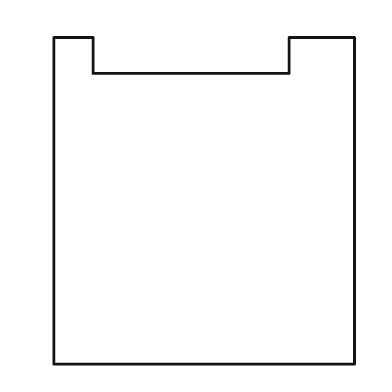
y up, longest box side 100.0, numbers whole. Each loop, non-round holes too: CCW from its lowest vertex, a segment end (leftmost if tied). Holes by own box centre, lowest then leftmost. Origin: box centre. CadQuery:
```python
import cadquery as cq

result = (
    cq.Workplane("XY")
    .moveTo(-46.0, -50.0)
    .lineTo(46.0, -50.0)
    .lineTo(46.0, 50.0)
    .lineTo(26.0, 50.0)
    .lineTo(26.0, 39.0)
    .lineTo(-34.0, 39.0)
    .lineTo(-34.0, 50.0)
    .lineTo(-46.0, 50.0)
    .close()
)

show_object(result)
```